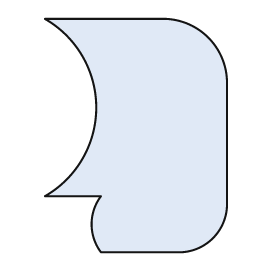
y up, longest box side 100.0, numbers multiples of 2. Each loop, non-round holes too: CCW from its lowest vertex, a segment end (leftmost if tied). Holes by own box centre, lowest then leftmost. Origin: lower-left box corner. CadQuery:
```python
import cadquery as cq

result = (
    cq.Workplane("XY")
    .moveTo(24.0, 0.0)
    .lineTo(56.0, 0.0)
    .threePointArc((72.0, 6.0), (78.0, 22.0))
    .lineTo(78.0, 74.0)
    .threePointArc((70.0, 92.0), (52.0, 100.0))
    .lineTo(0.0, 100.0)
    .threePointArc((22.0, 62.0), (0.0, 24.0))
    .lineTo(24.0, 24.0)
    .threePointArc((20.0, 12.0), (24.0, 0.0))
    .close()
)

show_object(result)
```